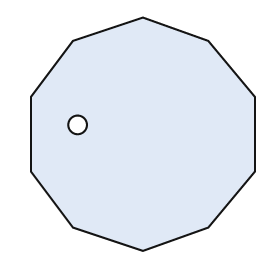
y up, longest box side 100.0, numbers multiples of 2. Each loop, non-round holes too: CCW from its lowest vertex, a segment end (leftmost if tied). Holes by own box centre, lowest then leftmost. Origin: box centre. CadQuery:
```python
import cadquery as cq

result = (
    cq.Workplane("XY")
    .moveTo(0.0, -50.0)
    .lineTo(28.0, -40.0)
    .lineTo(48.0, -16.0)
    .lineTo(48.0, 16.0)
    .lineTo(28.0, 40.0)
    .lineTo(0.0, 50.0)
    .lineTo(-30.0, 40.0)
    .lineTo(-48.0, 16.0)
    .lineTo(-48.0, -16.0)
    .lineTo(-30.0, -40.0)
    .close()
    .moveTo(-28.0, 4.0)
    .circle(4.0)
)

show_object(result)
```